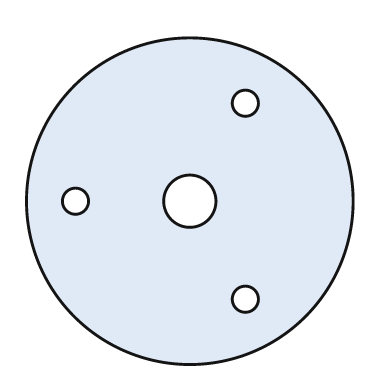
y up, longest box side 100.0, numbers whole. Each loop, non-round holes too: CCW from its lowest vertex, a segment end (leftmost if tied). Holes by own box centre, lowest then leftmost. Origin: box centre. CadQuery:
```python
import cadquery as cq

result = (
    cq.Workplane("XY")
    .moveTo(0.0, 0.0)
    .circle(50.0)
    .moveTo(17.0, -30.0)
    .circle(4.0)
    .moveTo(-35.0, 0.0)
    .circle(4.0)
    .moveTo(0.0, 0.0)
    .circle(8.0)
    .moveTo(17.0, 30.0)
    .circle(4.0)
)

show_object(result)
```